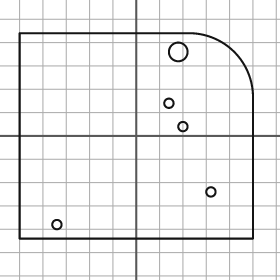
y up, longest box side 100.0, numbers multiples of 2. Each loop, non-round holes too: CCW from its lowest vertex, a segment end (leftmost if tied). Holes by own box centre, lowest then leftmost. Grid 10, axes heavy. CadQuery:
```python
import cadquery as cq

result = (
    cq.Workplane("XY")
    .moveTo(-50.0, -44.0)
    .lineTo(50.0, -44.0)
    .lineTo(50.0, 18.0)
    .threePointArc((42.0, 36.0), (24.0, 44.0))
    .lineTo(-50.0, 44.0)
    .close()
    .moveTo(-34.0, -38.0)
    .circle(2.0)
    .moveTo(32.0, -24.0)
    .circle(2.0)
    .moveTo(20.0, 4.0)
    .circle(2.0)
    .moveTo(14.0, 14.0)
    .circle(2.0)
    .moveTo(18.0, 36.0)
    .circle(4.0)
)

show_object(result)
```